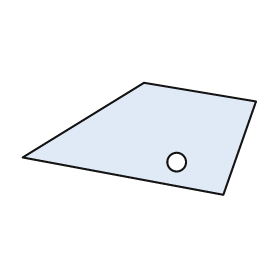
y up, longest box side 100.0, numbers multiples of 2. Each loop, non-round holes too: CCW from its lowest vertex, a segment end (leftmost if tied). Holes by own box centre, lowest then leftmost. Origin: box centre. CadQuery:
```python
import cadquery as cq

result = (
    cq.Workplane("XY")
    .moveTo(36.0, -24.0)
    .lineTo(50.0, 16.0)
    .lineTo(2.0, 24.0)
    .lineTo(-50.0, -8.0)
    .close()
    .moveTo(16.0, -10.0)
    .circle(4.0)
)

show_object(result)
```